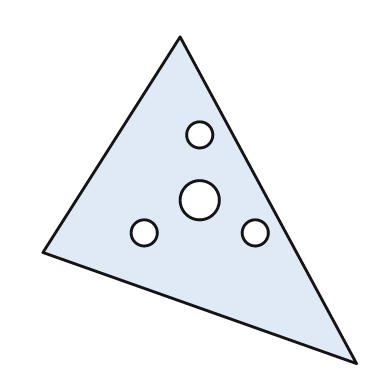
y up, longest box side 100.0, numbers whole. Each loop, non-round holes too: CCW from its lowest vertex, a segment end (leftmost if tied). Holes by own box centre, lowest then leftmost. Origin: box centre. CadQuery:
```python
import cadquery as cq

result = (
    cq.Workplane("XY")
    .moveTo(48.0, -50.0)
    .lineTo(-6.0, 50.0)
    .lineTo(-48.0, -16.0)
    .close()
    .moveTo(-17.0, -10.0)
    .circle(4.0)
    .moveTo(17.0, -10.0)
    .circle(4.0)
    .moveTo(0.0, 0.0)
    .circle(6.0)
    .moveTo(0.0, 20.0)
    .circle(4.0)
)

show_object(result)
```